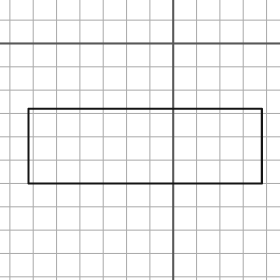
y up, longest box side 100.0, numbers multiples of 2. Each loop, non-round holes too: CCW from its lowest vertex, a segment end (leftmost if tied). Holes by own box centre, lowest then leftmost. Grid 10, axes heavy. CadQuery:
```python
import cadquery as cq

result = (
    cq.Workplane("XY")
    .moveTo(-62.0, -60.0)
    .lineTo(38.0, -60.0)
    .lineTo(38.0, -28.0)
    .lineTo(-62.0, -28.0)
    .close()
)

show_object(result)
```